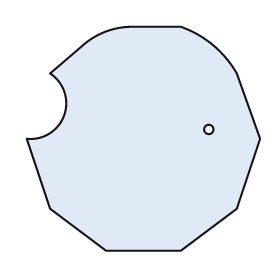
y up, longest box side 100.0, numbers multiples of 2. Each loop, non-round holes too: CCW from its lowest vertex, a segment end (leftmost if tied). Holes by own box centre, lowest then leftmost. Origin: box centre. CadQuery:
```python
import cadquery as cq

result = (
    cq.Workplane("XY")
    .moveTo(-16.0, -48.0)
    .lineTo(16.0, -48.0)
    .lineTo(40.0, -30.0)
    .lineTo(50.0, 0.0)
    .lineTo(40.0, 28.0)
    .threePointArc((30.0, 40.0), (16.0, 48.0))
    .lineTo(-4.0, 48.0)
    .threePointArc((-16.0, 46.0), (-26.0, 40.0))
    .lineTo(-40.0, 28.0)
    .threePointArc((-34.0, 10.0), (-50.0, 0.0))
    .lineTo(-40.0, -30.0)
    .close()
    .moveTo(28.0, 4.0)
    .circle(2.0)
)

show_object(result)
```